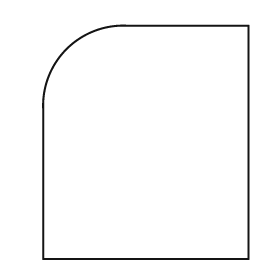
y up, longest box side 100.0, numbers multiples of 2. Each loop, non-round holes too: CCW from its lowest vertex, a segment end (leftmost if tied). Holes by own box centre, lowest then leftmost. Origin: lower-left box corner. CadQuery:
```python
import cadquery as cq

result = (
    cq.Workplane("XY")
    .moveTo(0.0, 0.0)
    .lineTo(88.0, 0.0)
    .lineTo(88.0, 100.0)
    .lineTo(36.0, 100.0)
    .threePointArc((10.0, 90.0), (0.0, 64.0))
    .close()
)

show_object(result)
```